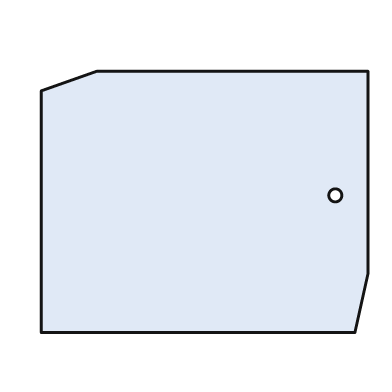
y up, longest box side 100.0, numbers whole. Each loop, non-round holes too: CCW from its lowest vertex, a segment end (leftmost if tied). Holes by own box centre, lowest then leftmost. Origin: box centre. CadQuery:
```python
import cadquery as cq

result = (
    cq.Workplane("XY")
    .moveTo(-50.0, -40.0)
    .lineTo(46.0, -40.0)
    .lineTo(50.0, -22.0)
    .lineTo(50.0, 40.0)
    .lineTo(-33.0, 40.0)
    .lineTo(-50.0, 34.0)
    .close()
    .moveTo(40.0, 2.0)
    .circle(2.0)
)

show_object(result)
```